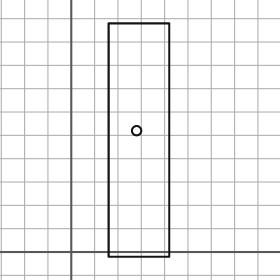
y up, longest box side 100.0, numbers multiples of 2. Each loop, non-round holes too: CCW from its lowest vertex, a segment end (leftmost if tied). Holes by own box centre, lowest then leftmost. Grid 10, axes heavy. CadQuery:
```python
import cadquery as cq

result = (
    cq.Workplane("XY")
    .moveTo(16.0, -2.0)
    .lineTo(42.0, -2.0)
    .lineTo(42.0, 98.0)
    .lineTo(16.0, 98.0)
    .close()
    .moveTo(28.0, 52.0)
    .circle(2.0)
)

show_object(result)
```